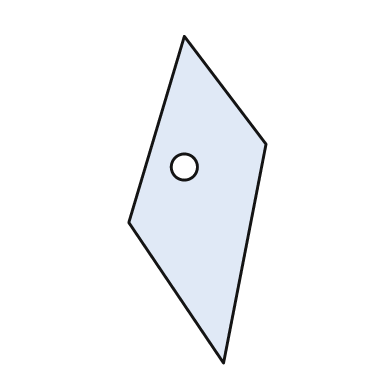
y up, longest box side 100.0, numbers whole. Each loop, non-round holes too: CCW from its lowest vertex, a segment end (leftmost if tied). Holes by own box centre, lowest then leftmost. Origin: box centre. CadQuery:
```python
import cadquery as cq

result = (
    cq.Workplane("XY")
    .moveTo(8.0, -50.0)
    .lineTo(21.0, 17.0)
    .lineTo(-4.0, 50.0)
    .lineTo(-21.0, -7.0)
    .close()
    .moveTo(-4.0, 10.0)
    .circle(4.0)
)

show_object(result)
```